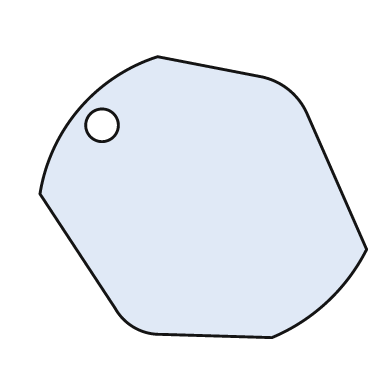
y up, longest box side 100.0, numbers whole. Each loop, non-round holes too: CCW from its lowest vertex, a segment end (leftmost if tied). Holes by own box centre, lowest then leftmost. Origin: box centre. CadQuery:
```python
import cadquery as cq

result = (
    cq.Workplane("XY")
    .moveTo(21.0, -43.0)
    .threePointArc((38.0, -32.0), (50.0, -16.0))
    .lineTo(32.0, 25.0)
    .threePointArc((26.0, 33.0), (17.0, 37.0))
    .lineTo(-14.0, 43.0)
    .threePointArc((-38.0, 27.0), (-50.0, 1.0))
    .lineTo(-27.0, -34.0)
    .threePointArc((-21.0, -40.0), (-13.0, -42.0))
    .close()
    .moveTo(-31.0, 22.0)
    .circle(5.0)
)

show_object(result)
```